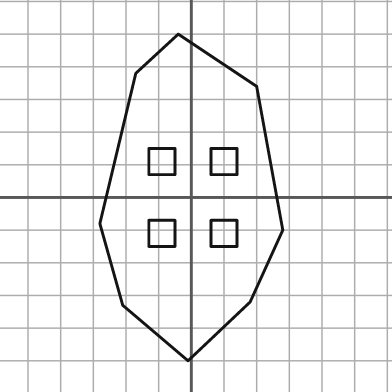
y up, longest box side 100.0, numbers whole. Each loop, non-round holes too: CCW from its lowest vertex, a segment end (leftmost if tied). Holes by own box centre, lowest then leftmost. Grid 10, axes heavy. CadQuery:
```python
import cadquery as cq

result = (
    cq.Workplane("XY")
    .moveTo(-1.0, -50.0)
    .lineTo(18.0, -32.0)
    .lineTo(28.0, -10.0)
    .lineTo(20.0, 34.0)
    .lineTo(-4.0, 50.0)
    .lineTo(-17.0, 38.0)
    .lineTo(-28.0, -8.0)
    .lineTo(-21.0, -33.0)
    .close()
    .moveTo(-13.0, -15.0)
    .lineTo(-5.0, -15.0)
    .lineTo(-5.0, -7.0)
    .lineTo(-13.0, -7.0)
    .close()
    .moveTo(6.0, -15.0)
    .lineTo(14.0, -15.0)
    .lineTo(14.0, -7.0)
    .lineTo(6.0, -7.0)
    .close()
    .moveTo(-13.0, 7.0)
    .lineTo(-5.0, 7.0)
    .lineTo(-5.0, 15.0)
    .lineTo(-13.0, 15.0)
    .close()
    .moveTo(6.0, 7.0)
    .lineTo(14.0, 7.0)
    .lineTo(14.0, 15.0)
    .lineTo(6.0, 15.0)
    .close()
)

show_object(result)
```